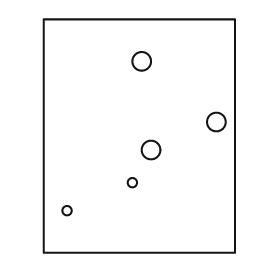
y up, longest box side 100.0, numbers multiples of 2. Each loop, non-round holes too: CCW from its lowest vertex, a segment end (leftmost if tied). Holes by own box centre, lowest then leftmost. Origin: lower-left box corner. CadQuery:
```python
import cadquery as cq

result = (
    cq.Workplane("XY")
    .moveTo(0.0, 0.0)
    .lineTo(82.0, 0.0)
    .lineTo(82.0, 100.0)
    .lineTo(0.0, 100.0)
    .close()
    .moveTo(10.0, 18.0)
    .circle(2.0)
    .moveTo(38.0, 30.0)
    .circle(2.0)
    .moveTo(46.0, 44.0)
    .circle(4.0)
    .moveTo(74.0, 56.0)
    .circle(4.0)
    .moveTo(42.0, 82.0)
    .circle(4.0)
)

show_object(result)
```